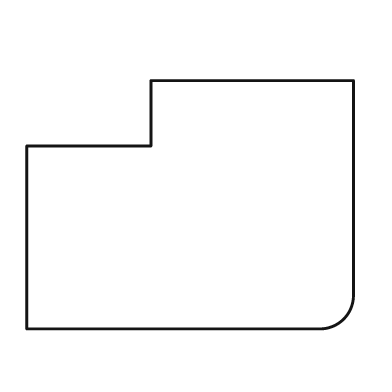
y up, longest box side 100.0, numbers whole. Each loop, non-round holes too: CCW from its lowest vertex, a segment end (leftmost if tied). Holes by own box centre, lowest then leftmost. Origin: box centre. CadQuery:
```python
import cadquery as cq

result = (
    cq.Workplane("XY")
    .moveTo(-50.0, -38.0)
    .lineTo(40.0, -38.0)
    .threePointArc((47.0, -35.0), (50.0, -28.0))
    .lineTo(50.0, 38.0)
    .lineTo(-12.0, 38.0)
    .lineTo(-12.0, 18.0)
    .lineTo(-50.0, 18.0)
    .close()
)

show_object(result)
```